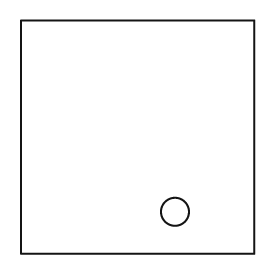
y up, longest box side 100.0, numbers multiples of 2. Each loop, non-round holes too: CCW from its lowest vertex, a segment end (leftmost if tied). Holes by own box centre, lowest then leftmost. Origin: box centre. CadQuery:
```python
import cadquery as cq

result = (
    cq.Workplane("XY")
    .moveTo(-50.0, -50.0)
    .lineTo(50.0, -50.0)
    .lineTo(50.0, 50.0)
    .lineTo(-50.0, 50.0)
    .close()
    .moveTo(16.0, -32.0)
    .circle(6.0)
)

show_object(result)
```